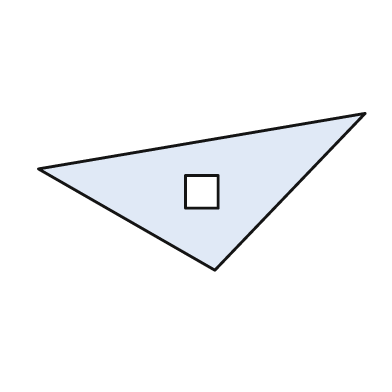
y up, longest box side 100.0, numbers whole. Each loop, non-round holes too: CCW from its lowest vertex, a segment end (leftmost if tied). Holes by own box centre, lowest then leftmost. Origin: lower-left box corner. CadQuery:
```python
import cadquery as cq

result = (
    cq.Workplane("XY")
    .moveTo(54.0, 0.0)
    .lineTo(100.0, 48.0)
    .lineTo(0.0, 31.0)
    .close()
    .moveTo(45.0, 19.0)
    .lineTo(55.0, 19.0)
    .lineTo(55.0, 29.0)
    .lineTo(45.0, 29.0)
    .close()
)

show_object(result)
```